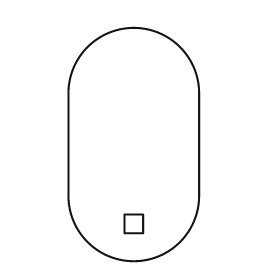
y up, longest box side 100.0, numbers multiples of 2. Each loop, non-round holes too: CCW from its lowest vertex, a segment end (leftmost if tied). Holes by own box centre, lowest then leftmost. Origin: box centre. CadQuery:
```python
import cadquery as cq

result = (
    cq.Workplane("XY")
    .moveTo(-28.0, -22.0)
    .threePointArc((0.0, -50.0), (28.0, -22.0))
    .lineTo(28.0, 22.0)
    .threePointArc((0.0, 50.0), (-28.0, 22.0))
    .close()
    .moveTo(-4.0, -38.0)
    .lineTo(4.0, -38.0)
    .lineTo(4.0, -30.0)
    .lineTo(-4.0, -30.0)
    .close()
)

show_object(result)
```